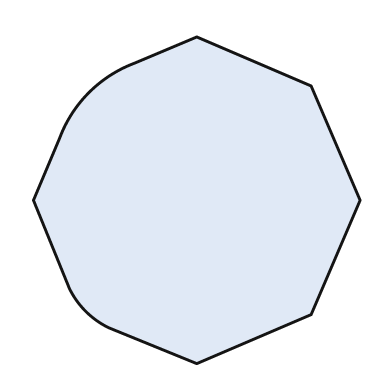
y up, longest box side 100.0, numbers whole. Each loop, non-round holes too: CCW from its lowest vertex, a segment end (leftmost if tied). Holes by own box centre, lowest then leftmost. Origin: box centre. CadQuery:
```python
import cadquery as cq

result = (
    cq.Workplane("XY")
    .moveTo(0.0, -50.0)
    .lineTo(35.0, -35.0)
    .lineTo(50.0, 0.0)
    .lineTo(35.0, 35.0)
    .lineTo(0.0, 50.0)
    .lineTo(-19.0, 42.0)
    .threePointArc((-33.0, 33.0), (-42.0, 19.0))
    .lineTo(-50.0, 0.0)
    .lineTo(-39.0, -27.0)
    .threePointArc((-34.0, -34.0), (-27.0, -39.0))
    .close()
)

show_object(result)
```